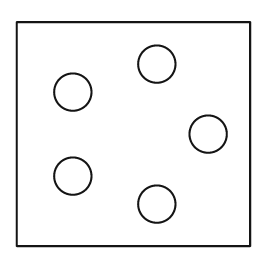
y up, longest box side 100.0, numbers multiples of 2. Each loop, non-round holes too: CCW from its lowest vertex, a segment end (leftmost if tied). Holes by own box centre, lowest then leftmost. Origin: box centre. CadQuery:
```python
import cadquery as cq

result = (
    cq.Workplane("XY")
    .moveTo(-50.0, -48.0)
    .lineTo(50.0, -48.0)
    .lineTo(50.0, 48.0)
    .lineTo(-50.0, 48.0)
    .close()
    .moveTo(10.0, -30.0)
    .circle(8.0)
    .moveTo(-26.0, -18.0)
    .circle(8.0)
    .moveTo(32.0, 0.0)
    .circle(8.0)
    .moveTo(-26.0, 18.0)
    .circle(8.0)
    .moveTo(10.0, 30.0)
    .circle(8.0)
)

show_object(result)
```